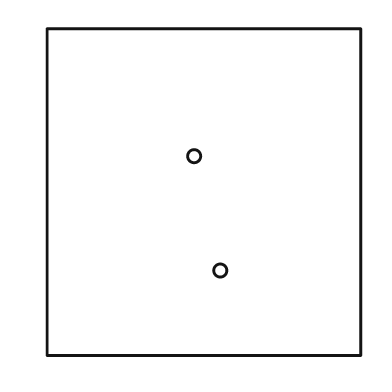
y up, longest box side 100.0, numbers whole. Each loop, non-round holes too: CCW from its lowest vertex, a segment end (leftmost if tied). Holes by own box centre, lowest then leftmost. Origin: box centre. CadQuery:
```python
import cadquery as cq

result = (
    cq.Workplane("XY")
    .moveTo(-48.0, -50.0)
    .lineTo(48.0, -50.0)
    .lineTo(48.0, 50.0)
    .lineTo(-48.0, 50.0)
    .close()
    .moveTo(5.0, -24.0)
    .circle(2.0)
    .moveTo(-3.0, 11.0)
    .circle(2.0)
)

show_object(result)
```